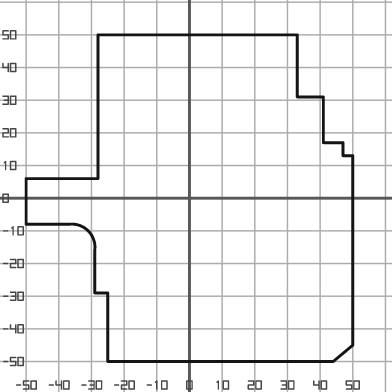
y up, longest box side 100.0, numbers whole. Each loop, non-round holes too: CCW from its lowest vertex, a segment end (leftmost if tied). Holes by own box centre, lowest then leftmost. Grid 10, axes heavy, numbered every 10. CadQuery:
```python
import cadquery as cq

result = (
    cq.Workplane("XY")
    .moveTo(-25.0, -50.0)
    .lineTo(44.0, -50.0)
    .lineTo(50.0, -45.0)
    .lineTo(50.0, 13.0)
    .lineTo(47.0, 13.0)
    .lineTo(47.0, 17.0)
    .lineTo(41.0, 17.0)
    .lineTo(41.0, 31.0)
    .lineTo(33.0, 31.0)
    .lineTo(33.0, 50.0)
    .lineTo(-28.0, 50.0)
    .lineTo(-28.0, 6.0)
    .lineTo(-50.0, 6.0)
    .lineTo(-50.0, -8.0)
    .lineTo(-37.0, -8.0)
    .threePointArc((-31.0, -10.0), (-29.0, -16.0))
    .lineTo(-29.0, -29.0)
    .lineTo(-25.0, -29.0)
    .close()
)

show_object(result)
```